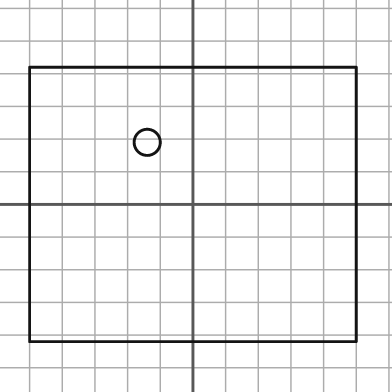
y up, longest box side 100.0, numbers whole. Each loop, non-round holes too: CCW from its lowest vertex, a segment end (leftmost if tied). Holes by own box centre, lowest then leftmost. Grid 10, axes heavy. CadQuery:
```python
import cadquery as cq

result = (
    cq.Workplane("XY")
    .moveTo(-50.0, -42.0)
    .lineTo(50.0, -42.0)
    .lineTo(50.0, 42.0)
    .lineTo(-50.0, 42.0)
    .close()
    .moveTo(-14.0, 19.0)
    .circle(4.0)
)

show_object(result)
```